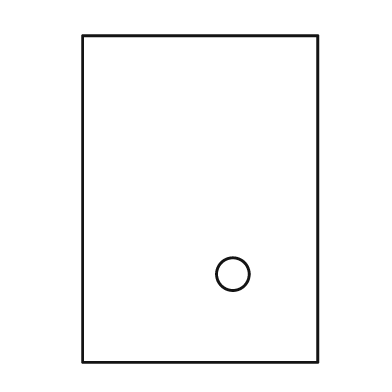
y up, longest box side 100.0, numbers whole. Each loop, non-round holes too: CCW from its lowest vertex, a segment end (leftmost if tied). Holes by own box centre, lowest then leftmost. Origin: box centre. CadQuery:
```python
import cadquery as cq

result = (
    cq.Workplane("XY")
    .moveTo(-36.0, -50.0)
    .lineTo(36.0, -50.0)
    .lineTo(36.0, 50.0)
    .lineTo(-36.0, 50.0)
    .close()
    .moveTo(10.0, -23.0)
    .circle(5.0)
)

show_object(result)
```